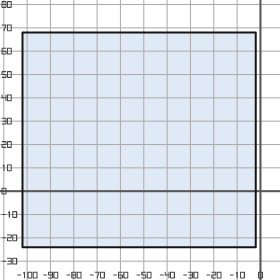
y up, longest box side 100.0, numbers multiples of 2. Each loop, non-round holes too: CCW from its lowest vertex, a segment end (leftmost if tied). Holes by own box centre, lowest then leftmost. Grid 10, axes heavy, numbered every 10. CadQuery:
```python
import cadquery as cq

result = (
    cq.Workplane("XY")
    .moveTo(-102.0, -24.0)
    .lineTo(-2.0, -24.0)
    .lineTo(-2.0, 68.0)
    .lineTo(-102.0, 68.0)
    .close()
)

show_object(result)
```